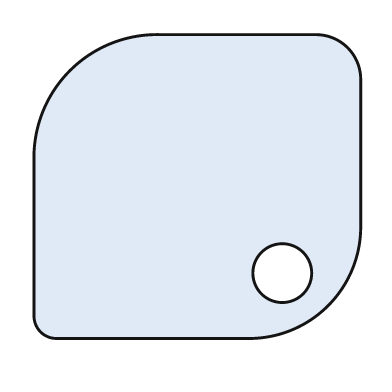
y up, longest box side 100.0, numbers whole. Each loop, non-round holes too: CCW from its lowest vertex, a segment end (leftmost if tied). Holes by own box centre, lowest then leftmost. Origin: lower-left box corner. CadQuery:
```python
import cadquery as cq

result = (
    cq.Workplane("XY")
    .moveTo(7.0, 0.0)
    .lineTo(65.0, 0.0)
    .threePointArc((90.0, 10.0), (100.0, 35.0))
    .lineTo(100.0, 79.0)
    .threePointArc((96.0, 89.0), (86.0, 93.0))
    .lineTo(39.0, 93.0)
    .threePointArc((11.0, 82.0), (0.0, 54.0))
    .lineTo(0.0, 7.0)
    .threePointArc((2.0, 2.0), (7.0, 0.0))
    .close()
    .moveTo(76.0, 20.0)
    .circle(9.0)
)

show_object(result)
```